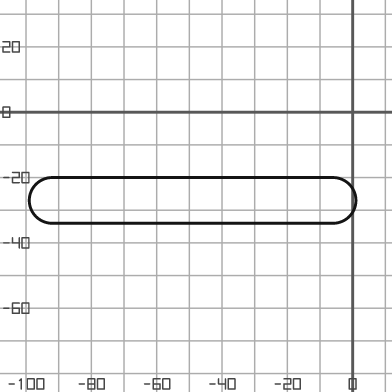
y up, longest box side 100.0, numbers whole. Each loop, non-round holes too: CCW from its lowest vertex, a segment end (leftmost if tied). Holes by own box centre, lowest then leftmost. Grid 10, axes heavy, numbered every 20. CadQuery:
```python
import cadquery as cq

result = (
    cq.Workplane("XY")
    .moveTo(-92.0, -34.0)
    .lineTo(-6.0, -34.0)
    .threePointArc((1.0, -27.0), (-6.0, -20.0))
    .lineTo(-92.0, -20.0)
    .threePointArc((-99.0, -27.0), (-92.0, -34.0))
    .close()
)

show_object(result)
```